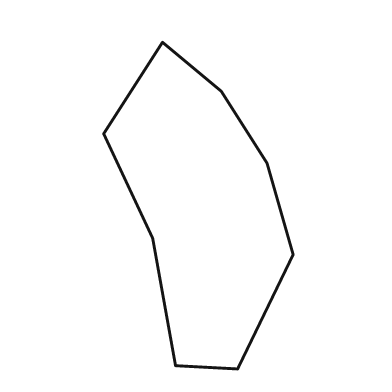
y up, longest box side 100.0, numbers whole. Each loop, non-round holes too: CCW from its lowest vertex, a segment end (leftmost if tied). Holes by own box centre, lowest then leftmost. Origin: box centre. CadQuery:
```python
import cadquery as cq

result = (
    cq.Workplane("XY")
    .moveTo(12.0, -50.0)
    .lineTo(29.0, -15.0)
    .lineTo(21.0, 13.0)
    .lineTo(7.0, 35.0)
    .lineTo(-11.0, 50.0)
    .lineTo(-29.0, 22.0)
    .lineTo(-14.0, -10.0)
    .lineTo(-7.0, -49.0)
    .close()
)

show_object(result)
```